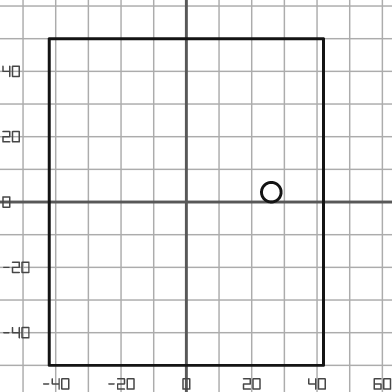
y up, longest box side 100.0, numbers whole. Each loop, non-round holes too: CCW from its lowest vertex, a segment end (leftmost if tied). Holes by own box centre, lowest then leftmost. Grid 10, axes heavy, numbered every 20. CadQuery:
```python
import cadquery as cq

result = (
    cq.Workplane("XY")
    .moveTo(-42.0, -50.0)
    .lineTo(42.0, -50.0)
    .lineTo(42.0, 50.0)
    .lineTo(-42.0, 50.0)
    .close()
    .moveTo(26.0, 3.0)
    .circle(3.0)
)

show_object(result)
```